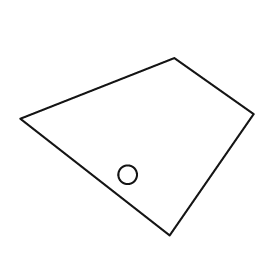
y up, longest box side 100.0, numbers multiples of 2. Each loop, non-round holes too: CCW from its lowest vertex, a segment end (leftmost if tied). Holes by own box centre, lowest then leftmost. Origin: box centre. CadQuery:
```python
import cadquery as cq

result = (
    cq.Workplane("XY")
    .moveTo(14.0, -38.0)
    .lineTo(50.0, 14.0)
    .lineTo(16.0, 38.0)
    .lineTo(-50.0, 12.0)
    .close()
    .moveTo(-4.0, -12.0)
    .circle(4.0)
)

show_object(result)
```